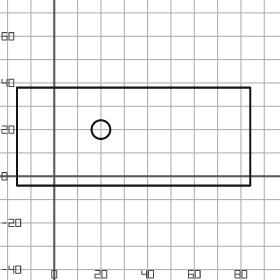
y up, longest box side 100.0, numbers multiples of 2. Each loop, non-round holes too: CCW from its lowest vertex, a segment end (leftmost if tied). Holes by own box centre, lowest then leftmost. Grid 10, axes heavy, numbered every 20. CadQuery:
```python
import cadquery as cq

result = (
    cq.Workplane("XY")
    .moveTo(-16.0, -4.0)
    .lineTo(84.0, -4.0)
    .lineTo(84.0, 38.0)
    .lineTo(-16.0, 38.0)
    .close()
    .moveTo(20.0, 20.0)
    .circle(4.0)
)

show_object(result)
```